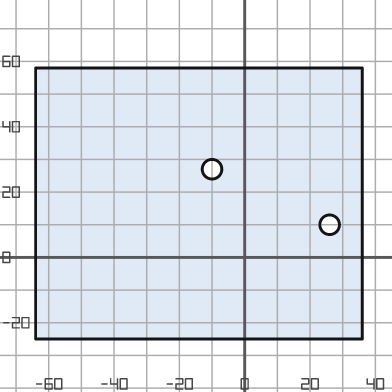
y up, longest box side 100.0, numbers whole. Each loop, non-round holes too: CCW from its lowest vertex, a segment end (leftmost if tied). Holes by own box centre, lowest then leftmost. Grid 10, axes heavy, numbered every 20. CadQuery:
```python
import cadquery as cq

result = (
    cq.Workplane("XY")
    .moveTo(-64.0, -25.0)
    .lineTo(36.0, -25.0)
    .lineTo(36.0, 58.0)
    .lineTo(-64.0, 58.0)
    .close()
    .moveTo(26.0, 10.0)
    .circle(3.0)
    .moveTo(-10.0, 27.0)
    .circle(3.0)
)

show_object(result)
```